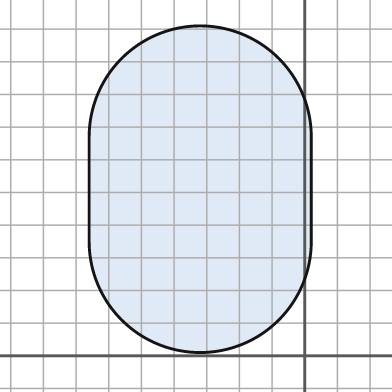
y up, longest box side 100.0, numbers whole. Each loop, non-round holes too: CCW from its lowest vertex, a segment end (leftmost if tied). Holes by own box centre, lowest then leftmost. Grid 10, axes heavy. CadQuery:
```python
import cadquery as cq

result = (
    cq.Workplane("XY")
    .moveTo(-66.0, 35.0)
    .threePointArc((-32.0, 1.0), (2.0, 35.0))
    .lineTo(2.0, 67.0)
    .threePointArc((-32.0, 101.0), (-66.0, 67.0))
    .close()
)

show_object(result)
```